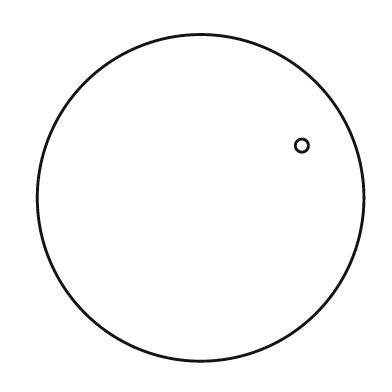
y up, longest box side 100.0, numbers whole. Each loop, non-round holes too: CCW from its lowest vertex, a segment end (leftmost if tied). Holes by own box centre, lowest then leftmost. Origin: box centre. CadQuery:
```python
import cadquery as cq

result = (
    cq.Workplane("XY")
    .moveTo(0.0, 0.0)
    .circle(50.0)
    .moveTo(31.0, 16.0)
    .circle(2.0)
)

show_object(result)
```